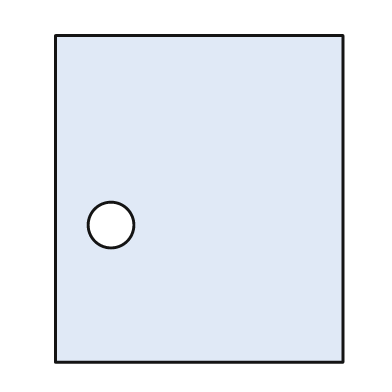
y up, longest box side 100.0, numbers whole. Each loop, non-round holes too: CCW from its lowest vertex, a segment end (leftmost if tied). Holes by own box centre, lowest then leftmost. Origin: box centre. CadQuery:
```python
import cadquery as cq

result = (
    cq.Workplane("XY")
    .moveTo(-44.0, -50.0)
    .lineTo(44.0, -50.0)
    .lineTo(44.0, 50.0)
    .lineTo(-44.0, 50.0)
    .close()
    .moveTo(-27.0, -8.0)
    .circle(7.0)
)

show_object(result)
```